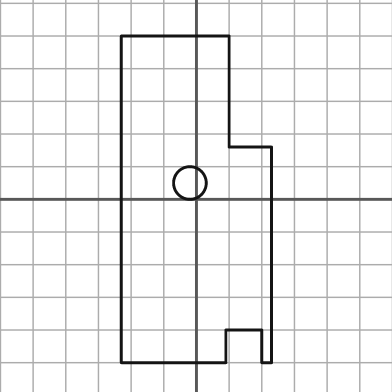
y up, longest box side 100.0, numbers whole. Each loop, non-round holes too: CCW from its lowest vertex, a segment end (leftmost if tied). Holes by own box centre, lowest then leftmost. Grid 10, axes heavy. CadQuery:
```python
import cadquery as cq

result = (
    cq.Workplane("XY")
    .moveTo(-23.0, -50.0)
    .lineTo(9.0, -50.0)
    .lineTo(9.0, -40.0)
    .lineTo(20.0, -40.0)
    .lineTo(20.0, -50.0)
    .lineTo(23.0, -50.0)
    .lineTo(23.0, 16.0)
    .lineTo(10.0, 16.0)
    .lineTo(10.0, 50.0)
    .lineTo(-23.0, 50.0)
    .close()
    .moveTo(-2.0, 5.0)
    .circle(5.0)
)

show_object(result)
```